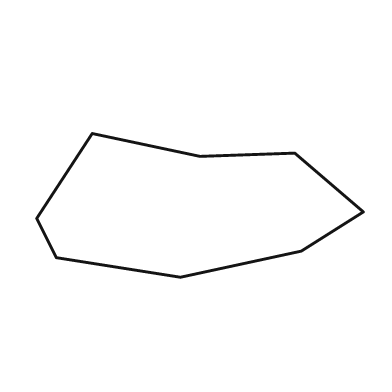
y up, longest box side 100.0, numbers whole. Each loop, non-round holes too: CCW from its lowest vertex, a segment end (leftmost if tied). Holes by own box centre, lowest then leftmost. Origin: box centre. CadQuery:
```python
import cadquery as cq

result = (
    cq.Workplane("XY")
    .moveTo(-6.0, -22.0)
    .lineTo(31.0, -14.0)
    .lineTo(50.0, -2.0)
    .lineTo(29.0, 16.0)
    .lineTo(0.0, 15.0)
    .lineTo(-33.0, 22.0)
    .lineTo(-50.0, -4.0)
    .lineTo(-44.0, -16.0)
    .close()
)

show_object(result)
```